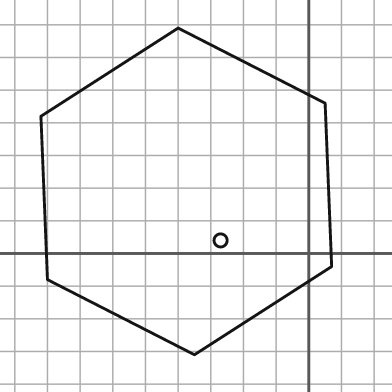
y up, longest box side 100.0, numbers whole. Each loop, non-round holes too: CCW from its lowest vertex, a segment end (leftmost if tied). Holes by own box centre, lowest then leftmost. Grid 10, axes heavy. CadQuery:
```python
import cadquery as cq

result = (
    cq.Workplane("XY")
    .moveTo(-35.0, -31.0)
    .lineTo(7.0, -4.0)
    .lineTo(5.0, 46.0)
    .lineTo(-40.0, 69.0)
    .lineTo(-82.0, 42.0)
    .lineTo(-80.0, -8.0)
    .close()
    .moveTo(-27.0, 4.0)
    .circle(2.0)
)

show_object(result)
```